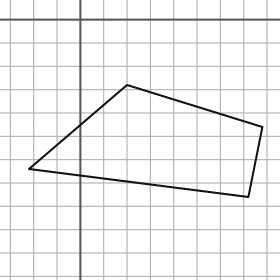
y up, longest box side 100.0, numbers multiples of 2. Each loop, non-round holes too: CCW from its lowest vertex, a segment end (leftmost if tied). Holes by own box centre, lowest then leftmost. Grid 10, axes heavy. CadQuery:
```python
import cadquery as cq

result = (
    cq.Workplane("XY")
    .moveTo(72.0, -76.0)
    .lineTo(78.0, -46.0)
    .lineTo(20.0, -28.0)
    .lineTo(-22.0, -64.0)
    .close()
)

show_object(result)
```